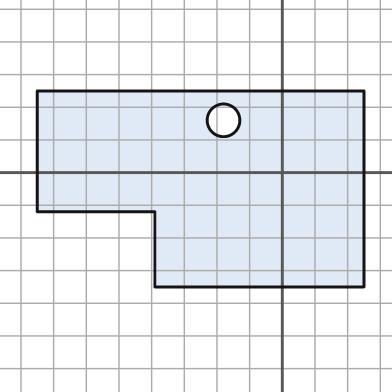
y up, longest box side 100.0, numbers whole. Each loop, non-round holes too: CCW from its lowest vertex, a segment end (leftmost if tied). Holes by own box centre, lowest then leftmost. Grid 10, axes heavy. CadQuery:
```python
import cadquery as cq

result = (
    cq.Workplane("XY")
    .moveTo(-39.0, -35.0)
    .lineTo(25.0, -35.0)
    .lineTo(25.0, 25.0)
    .lineTo(-75.0, 25.0)
    .lineTo(-75.0, -12.0)
    .lineTo(-39.0, -12.0)
    .close()
    .moveTo(-18.0, 16.0)
    .circle(5.0)
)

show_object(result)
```